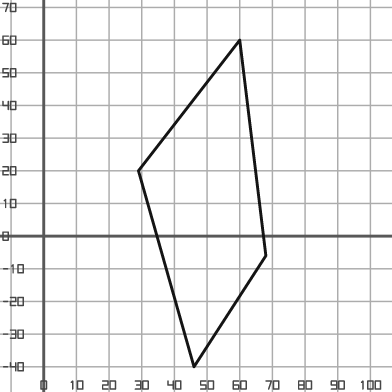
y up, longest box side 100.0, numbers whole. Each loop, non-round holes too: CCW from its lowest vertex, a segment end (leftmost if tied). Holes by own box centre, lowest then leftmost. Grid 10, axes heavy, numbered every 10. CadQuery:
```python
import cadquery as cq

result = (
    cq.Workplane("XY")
    .moveTo(46.0, -40.0)
    .lineTo(68.0, -6.0)
    .lineTo(60.0, 60.0)
    .lineTo(29.0, 20.0)
    .close()
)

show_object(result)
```